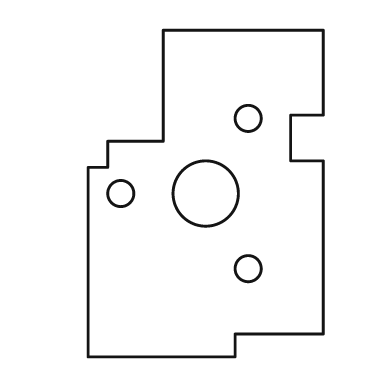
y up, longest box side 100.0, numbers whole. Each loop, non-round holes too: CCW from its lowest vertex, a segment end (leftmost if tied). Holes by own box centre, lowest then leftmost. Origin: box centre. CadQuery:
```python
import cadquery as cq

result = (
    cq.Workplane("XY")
    .moveTo(-36.0, -50.0)
    .lineTo(9.0, -50.0)
    .lineTo(9.0, -43.0)
    .lineTo(36.0, -43.0)
    .lineTo(36.0, 10.0)
    .lineTo(26.0, 10.0)
    .lineTo(26.0, 24.0)
    .lineTo(36.0, 24.0)
    .lineTo(36.0, 50.0)
    .lineTo(-13.0, 50.0)
    .lineTo(-13.0, 16.0)
    .lineTo(-30.0, 16.0)
    .lineTo(-30.0, 8.0)
    .lineTo(-36.0, 8.0)
    .close()
    .moveTo(13.0, -23.0)
    .circle(4.0)
    .moveTo(-26.0, 0.0)
    .circle(4.0)
    .moveTo(0.0, 0.0)
    .circle(10.0)
    .moveTo(13.0, 23.0)
    .circle(4.0)
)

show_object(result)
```